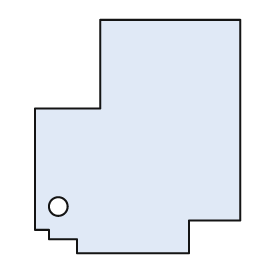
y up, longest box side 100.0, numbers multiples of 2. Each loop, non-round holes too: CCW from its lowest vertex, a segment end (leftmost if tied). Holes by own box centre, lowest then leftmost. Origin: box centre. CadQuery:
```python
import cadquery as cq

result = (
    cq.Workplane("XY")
    .moveTo(-26.0, -50.0)
    .lineTo(22.0, -50.0)
    .lineTo(22.0, -36.0)
    .lineTo(44.0, -36.0)
    .lineTo(44.0, 50.0)
    .lineTo(-16.0, 50.0)
    .lineTo(-16.0, 12.0)
    .lineTo(-44.0, 12.0)
    .lineTo(-44.0, -40.0)
    .lineTo(-38.0, -40.0)
    .lineTo(-38.0, -44.0)
    .lineTo(-26.0, -44.0)
    .close()
    .moveTo(-34.0, -30.0)
    .circle(4.0)
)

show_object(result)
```